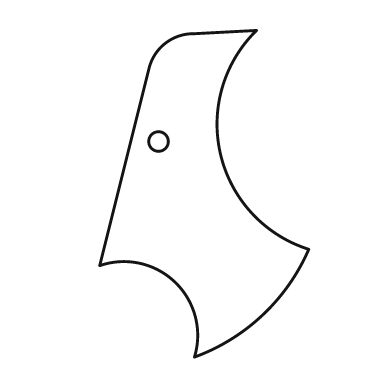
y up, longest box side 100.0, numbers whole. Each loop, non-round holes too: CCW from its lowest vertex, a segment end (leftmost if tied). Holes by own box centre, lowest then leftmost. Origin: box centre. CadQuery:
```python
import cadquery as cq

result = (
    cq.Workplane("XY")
    .moveTo(-3.0, -50.0)
    .threePointArc((18.0, -37.0), (32.0, -17.0))
    .threePointArc((5.0, 12.0), (16.0, 50.0))
    .lineTo(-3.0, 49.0)
    .threePointArc((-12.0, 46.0), (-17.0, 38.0))
    .lineTo(-32.0, -22.0)
    .threePointArc((-9.0, -27.0), (-3.0, -50.0))
    .close()
    .moveTo(-14.0, 16.0)
    .circle(3.0)
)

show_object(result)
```